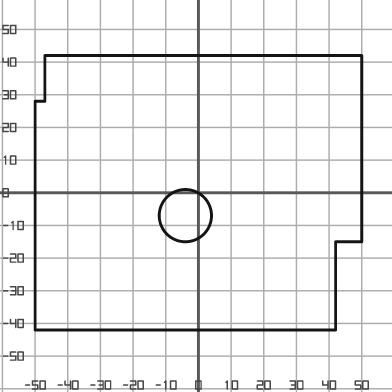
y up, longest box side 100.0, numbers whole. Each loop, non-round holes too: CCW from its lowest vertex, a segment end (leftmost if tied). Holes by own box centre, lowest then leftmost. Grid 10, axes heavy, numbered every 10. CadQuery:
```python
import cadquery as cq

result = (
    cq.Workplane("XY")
    .moveTo(-50.0, -42.0)
    .lineTo(42.0, -42.0)
    .lineTo(42.0, -15.0)
    .lineTo(50.0, -15.0)
    .lineTo(50.0, 42.0)
    .lineTo(-47.0, 42.0)
    .lineTo(-47.0, 28.0)
    .lineTo(-50.0, 28.0)
    .close()
    .moveTo(-4.0, -7.0)
    .circle(8.0)
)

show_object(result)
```